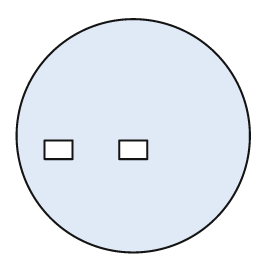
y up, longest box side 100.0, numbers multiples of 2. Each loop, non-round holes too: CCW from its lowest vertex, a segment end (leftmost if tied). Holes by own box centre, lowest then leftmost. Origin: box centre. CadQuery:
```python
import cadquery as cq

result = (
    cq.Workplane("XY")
    .moveTo(0.0, 0.0)
    .circle(50.0)
    .moveTo(-38.0, -10.0)
    .lineTo(-26.0, -10.0)
    .lineTo(-26.0, -2.0)
    .lineTo(-38.0, -2.0)
    .close()
    .moveTo(-6.0, -10.0)
    .lineTo(6.0, -10.0)
    .lineTo(6.0, -2.0)
    .lineTo(-6.0, -2.0)
    .close()
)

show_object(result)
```